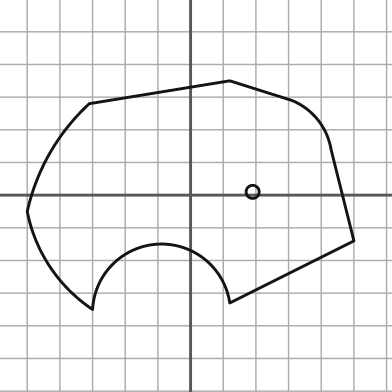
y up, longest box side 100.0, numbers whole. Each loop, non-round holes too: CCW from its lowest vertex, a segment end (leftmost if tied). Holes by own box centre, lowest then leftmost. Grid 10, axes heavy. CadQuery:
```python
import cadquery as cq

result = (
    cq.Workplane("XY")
    .moveTo(-30.0, -35.0)
    .threePointArc((-10.0, -15.0), (12.0, -33.0))
    .lineTo(50.0, -14.0)
    .lineTo(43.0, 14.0)
    .threePointArc((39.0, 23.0), (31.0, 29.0))
    .lineTo(12.0, 35.0)
    .lineTo(-31.0, 28.0)
    .threePointArc((-43.0, 13.0), (-50.0, -5.0))
    .threePointArc((-43.0, -22.0), (-30.0, -35.0))
    .close()
    .moveTo(19.0, 1.0)
    .circle(2.0)
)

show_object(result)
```